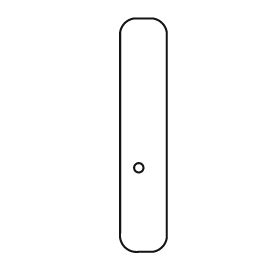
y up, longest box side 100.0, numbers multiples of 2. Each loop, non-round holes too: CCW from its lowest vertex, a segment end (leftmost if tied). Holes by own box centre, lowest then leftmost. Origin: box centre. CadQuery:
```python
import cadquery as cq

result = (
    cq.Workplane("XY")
    .moveTo(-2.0, -50.0)
    .lineTo(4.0, -50.0)
    .threePointArc((8.0, -48.0), (10.0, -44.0))
    .lineTo(10.0, 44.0)
    .threePointArc((8.0, 48.0), (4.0, 50.0))
    .lineTo(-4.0, 50.0)
    .threePointArc((-8.0, 48.0), (-10.0, 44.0))
    .lineTo(-10.0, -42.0)
    .threePointArc((-8.0, -48.0), (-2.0, -50.0))
    .close()
    .moveTo(-2.0, -14.0)
    .circle(2.0)
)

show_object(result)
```